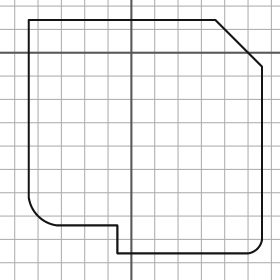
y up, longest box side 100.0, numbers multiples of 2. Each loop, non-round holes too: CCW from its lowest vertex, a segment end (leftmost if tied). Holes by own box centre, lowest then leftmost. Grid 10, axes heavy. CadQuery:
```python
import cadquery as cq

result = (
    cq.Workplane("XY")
    .moveTo(-6.0, -86.0)
    .lineTo(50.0, -86.0)
    .threePointArc((54.0, -84.0), (56.0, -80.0))
    .lineTo(56.0, -6.0)
    .lineTo(36.0, 14.0)
    .lineTo(-44.0, 14.0)
    .lineTo(-44.0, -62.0)
    .threePointArc((-40.0, -70.0), (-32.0, -74.0))
    .lineTo(-6.0, -74.0)
    .close()
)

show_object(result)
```